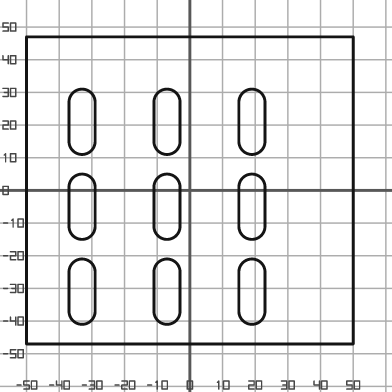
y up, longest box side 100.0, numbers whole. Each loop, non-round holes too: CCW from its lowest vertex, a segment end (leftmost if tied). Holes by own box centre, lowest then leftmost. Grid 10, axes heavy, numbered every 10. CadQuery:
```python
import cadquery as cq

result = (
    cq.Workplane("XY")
    .moveTo(-50.0, -47.0)
    .lineTo(50.0, -47.0)
    .lineTo(50.0, 47.0)
    .lineTo(-50.0, 47.0)
    .close()
    .moveTo(-37.0, -37.0)
    .threePointArc((-33.0, -41.0), (-29.0, -37.0))
    .lineTo(-29.0, -25.0)
    .threePointArc((-33.0, -21.0), (-37.0, -25.0))
    .close()
    .moveTo(-11.0, -37.0)
    .threePointArc((-7.0, -41.0), (-3.0, -37.0))
    .lineTo(-3.0, -25.0)
    .threePointArc((-7.0, -21.0), (-11.0, -25.0))
    .close()
    .moveTo(15.0, -37.0)
    .threePointArc((19.0, -41.0), (23.0, -37.0))
    .lineTo(23.0, -25.0)
    .threePointArc((19.0, -21.0), (15.0, -25.0))
    .close()
    .moveTo(-37.0, -11.0)
    .threePointArc((-33.0, -15.0), (-29.0, -11.0))
    .lineTo(-29.0, 1.0)
    .threePointArc((-33.0, 5.0), (-37.0, 1.0))
    .close()
    .moveTo(-11.0, -11.0)
    .threePointArc((-7.0, -15.0), (-3.0, -11.0))
    .lineTo(-3.0, 1.0)
    .threePointArc((-7.0, 5.0), (-11.0, 1.0))
    .close()
    .moveTo(15.0, -11.0)
    .threePointArc((19.0, -15.0), (23.0, -11.0))
    .lineTo(23.0, 1.0)
    .threePointArc((19.0, 5.0), (15.0, 1.0))
    .close()
    .moveTo(-37.0, 15.0)
    .threePointArc((-33.0, 11.0), (-29.0, 15.0))
    .lineTo(-29.0, 27.0)
    .threePointArc((-33.0, 31.0), (-37.0, 27.0))
    .close()
    .moveTo(-11.0, 15.0)
    .threePointArc((-7.0, 11.0), (-3.0, 15.0))
    .lineTo(-3.0, 27.0)
    .threePointArc((-7.0, 31.0), (-11.0, 27.0))
    .close()
    .moveTo(15.0, 15.0)
    .threePointArc((19.0, 11.0), (23.0, 15.0))
    .lineTo(23.0, 27.0)
    .threePointArc((19.0, 31.0), (15.0, 27.0))
    .close()
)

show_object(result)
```